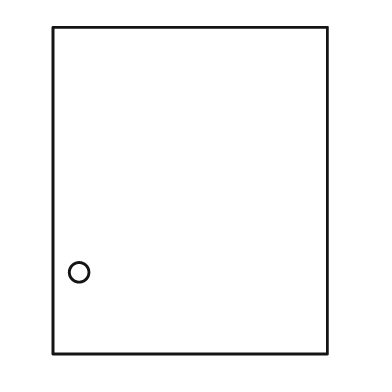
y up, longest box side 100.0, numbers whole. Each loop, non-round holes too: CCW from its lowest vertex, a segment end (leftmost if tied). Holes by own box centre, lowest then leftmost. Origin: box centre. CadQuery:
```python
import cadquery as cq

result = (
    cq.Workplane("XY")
    .moveTo(-42.0, -50.0)
    .lineTo(42.0, -50.0)
    .lineTo(42.0, 50.0)
    .lineTo(-42.0, 50.0)
    .close()
    .moveTo(-34.0, -25.0)
    .circle(3.0)
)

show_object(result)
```